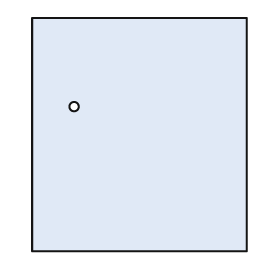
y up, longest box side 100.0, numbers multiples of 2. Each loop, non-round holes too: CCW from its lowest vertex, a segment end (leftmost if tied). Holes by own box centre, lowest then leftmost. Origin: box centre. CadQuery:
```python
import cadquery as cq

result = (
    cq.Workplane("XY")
    .moveTo(-46.0, -50.0)
    .lineTo(46.0, -50.0)
    .lineTo(46.0, 50.0)
    .lineTo(-46.0, 50.0)
    .close()
    .moveTo(-28.0, 12.0)
    .circle(2.0)
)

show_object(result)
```